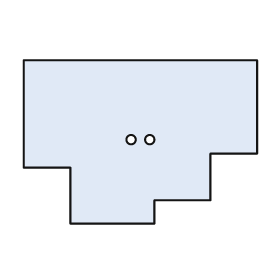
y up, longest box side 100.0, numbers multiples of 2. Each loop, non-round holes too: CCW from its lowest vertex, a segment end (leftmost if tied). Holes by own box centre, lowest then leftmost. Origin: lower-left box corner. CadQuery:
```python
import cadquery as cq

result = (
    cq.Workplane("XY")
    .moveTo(20.0, 0.0)
    .lineTo(56.0, 0.0)
    .lineTo(56.0, 10.0)
    .lineTo(80.0, 10.0)
    .lineTo(80.0, 30.0)
    .lineTo(100.0, 30.0)
    .lineTo(100.0, 70.0)
    .lineTo(0.0, 70.0)
    .lineTo(0.0, 24.0)
    .lineTo(20.0, 24.0)
    .close()
    .moveTo(46.0, 36.0)
    .circle(2.0)
    .moveTo(54.0, 36.0)
    .circle(2.0)
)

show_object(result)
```